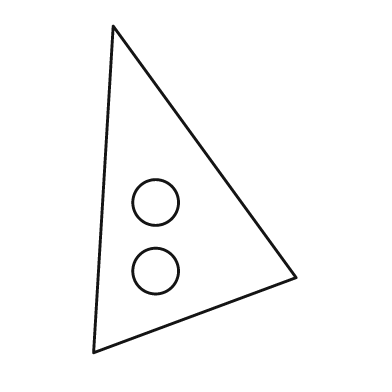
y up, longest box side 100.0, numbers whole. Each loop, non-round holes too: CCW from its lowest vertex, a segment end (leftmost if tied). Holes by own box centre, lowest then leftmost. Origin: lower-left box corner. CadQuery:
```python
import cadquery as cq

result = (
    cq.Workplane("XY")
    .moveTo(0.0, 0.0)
    .lineTo(62.0, 23.0)
    .lineTo(6.0, 100.0)
    .close()
    .moveTo(19.0, 25.0)
    .circle(7.0)
    .moveTo(19.0, 46.0)
    .circle(7.0)
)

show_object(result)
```